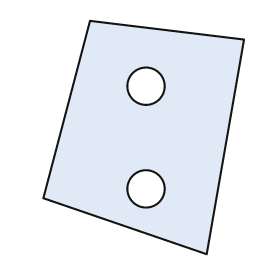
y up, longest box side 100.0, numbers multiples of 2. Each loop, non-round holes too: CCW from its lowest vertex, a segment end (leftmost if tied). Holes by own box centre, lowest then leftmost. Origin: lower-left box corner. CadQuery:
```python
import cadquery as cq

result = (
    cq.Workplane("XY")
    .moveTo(70.0, 0.0)
    .lineTo(86.0, 92.0)
    .lineTo(20.0, 100.0)
    .lineTo(0.0, 24.0)
    .close()
    .moveTo(44.0, 28.0)
    .circle(8.0)
    .moveTo(44.0, 72.0)
    .circle(8.0)
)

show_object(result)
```